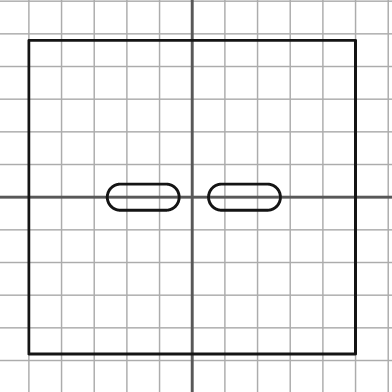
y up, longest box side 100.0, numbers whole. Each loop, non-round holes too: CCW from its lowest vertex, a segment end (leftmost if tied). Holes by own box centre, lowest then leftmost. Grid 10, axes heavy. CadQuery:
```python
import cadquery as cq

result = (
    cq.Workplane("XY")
    .moveTo(-50.0, -48.0)
    .lineTo(50.0, -48.0)
    .lineTo(50.0, 48.0)
    .lineTo(-50.0, 48.0)
    .close()
    .moveTo(-22.0, -4.0)
    .lineTo(-8.0, -4.0)
    .threePointArc((-4.0, 0.0), (-8.0, 4.0))
    .lineTo(-22.0, 4.0)
    .threePointArc((-26.0, 0.0), (-22.0, -4.0))
    .close()
    .moveTo(9.0, -4.0)
    .lineTo(23.0, -4.0)
    .threePointArc((27.0, 0.0), (23.0, 4.0))
    .lineTo(9.0, 4.0)
    .threePointArc((5.0, 0.0), (9.0, -4.0))
    .close()
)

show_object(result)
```